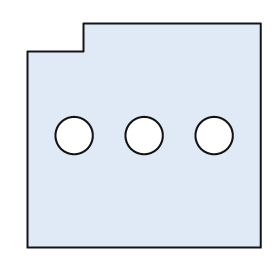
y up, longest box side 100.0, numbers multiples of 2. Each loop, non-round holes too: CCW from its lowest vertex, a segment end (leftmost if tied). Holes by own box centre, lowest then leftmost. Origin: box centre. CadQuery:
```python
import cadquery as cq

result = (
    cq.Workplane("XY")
    .moveTo(-50.0, -48.0)
    .lineTo(50.0, -48.0)
    .lineTo(50.0, 48.0)
    .lineTo(-26.0, 48.0)
    .lineTo(-26.0, 36.0)
    .lineTo(-50.0, 36.0)
    .close()
    .moveTo(-30.0, 0.0)
    .circle(8.0)
    .moveTo(0.0, 0.0)
    .circle(8.0)
    .moveTo(30.0, 0.0)
    .circle(8.0)
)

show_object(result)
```